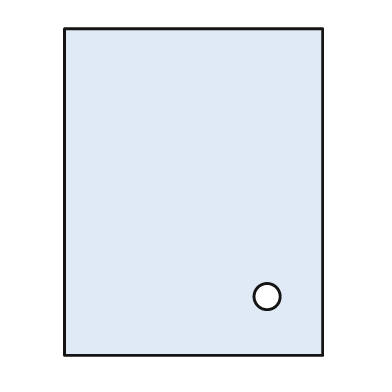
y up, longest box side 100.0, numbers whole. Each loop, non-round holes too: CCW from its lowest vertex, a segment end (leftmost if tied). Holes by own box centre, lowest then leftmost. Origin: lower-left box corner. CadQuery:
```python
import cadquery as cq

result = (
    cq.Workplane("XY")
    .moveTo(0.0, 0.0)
    .lineTo(79.0, 0.0)
    .lineTo(79.0, 100.0)
    .lineTo(0.0, 100.0)
    .close()
    .moveTo(62.0, 18.0)
    .circle(4.0)
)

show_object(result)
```